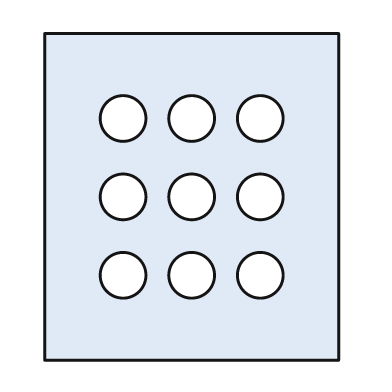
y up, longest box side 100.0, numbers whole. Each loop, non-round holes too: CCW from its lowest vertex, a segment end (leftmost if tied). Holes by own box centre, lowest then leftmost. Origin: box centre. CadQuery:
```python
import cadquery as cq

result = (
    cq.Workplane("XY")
    .moveTo(-45.0, -50.0)
    .lineTo(45.0, -50.0)
    .lineTo(45.0, 50.0)
    .lineTo(-45.0, 50.0)
    .close()
    .moveTo(-21.0, -24.0)
    .circle(7.0)
    .moveTo(0.0, -24.0)
    .circle(7.0)
    .moveTo(21.0, -24.0)
    .circle(7.0)
    .moveTo(-21.0, 0.0)
    .circle(7.0)
    .moveTo(0.0, 0.0)
    .circle(7.0)
    .moveTo(21.0, 0.0)
    .circle(7.0)
    .moveTo(-21.0, 24.0)
    .circle(7.0)
    .moveTo(0.0, 24.0)
    .circle(7.0)
    .moveTo(21.0, 24.0)
    .circle(7.0)
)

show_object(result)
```